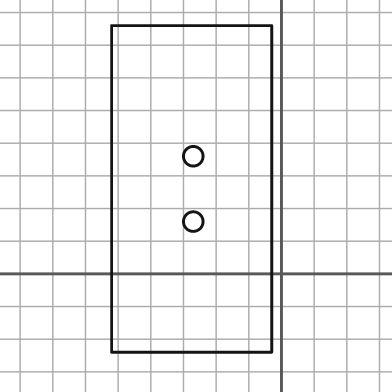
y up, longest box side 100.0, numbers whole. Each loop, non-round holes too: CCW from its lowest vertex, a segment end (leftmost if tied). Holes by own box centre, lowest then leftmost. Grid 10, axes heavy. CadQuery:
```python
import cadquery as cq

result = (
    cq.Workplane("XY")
    .moveTo(-52.0, -24.0)
    .lineTo(-3.0, -24.0)
    .lineTo(-3.0, 76.0)
    .lineTo(-52.0, 76.0)
    .close()
    .moveTo(-27.0, 16.0)
    .circle(3.0)
    .moveTo(-27.0, 36.0)
    .circle(3.0)
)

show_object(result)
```